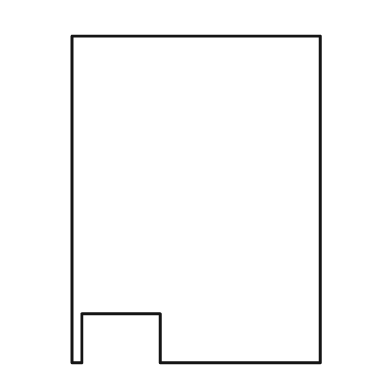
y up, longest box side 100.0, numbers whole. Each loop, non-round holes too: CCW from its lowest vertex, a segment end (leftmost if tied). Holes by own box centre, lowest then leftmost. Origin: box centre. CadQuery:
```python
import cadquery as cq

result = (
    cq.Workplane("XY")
    .moveTo(-38.0, -50.0)
    .lineTo(-35.0, -50.0)
    .lineTo(-35.0, -35.0)
    .lineTo(-11.0, -35.0)
    .lineTo(-11.0, -50.0)
    .lineTo(38.0, -50.0)
    .lineTo(38.0, 50.0)
    .lineTo(-38.0, 50.0)
    .close()
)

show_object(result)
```